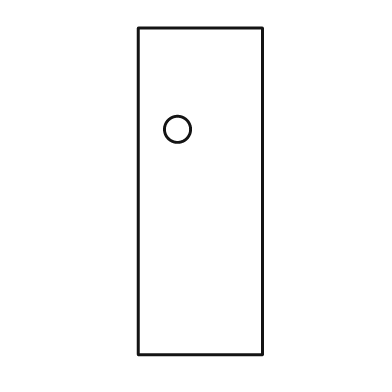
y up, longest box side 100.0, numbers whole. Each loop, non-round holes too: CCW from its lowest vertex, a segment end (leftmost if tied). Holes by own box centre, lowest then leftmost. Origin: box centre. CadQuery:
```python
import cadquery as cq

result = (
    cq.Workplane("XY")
    .moveTo(-19.0, -50.0)
    .lineTo(19.0, -50.0)
    .lineTo(19.0, 50.0)
    .lineTo(-19.0, 50.0)
    .close()
    .moveTo(-7.0, 19.0)
    .circle(4.0)
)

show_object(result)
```